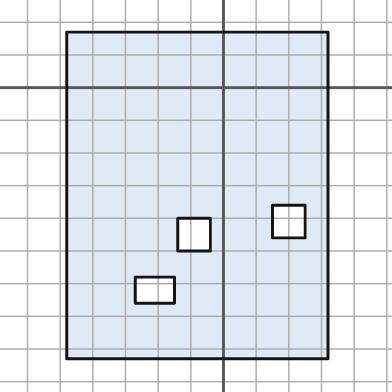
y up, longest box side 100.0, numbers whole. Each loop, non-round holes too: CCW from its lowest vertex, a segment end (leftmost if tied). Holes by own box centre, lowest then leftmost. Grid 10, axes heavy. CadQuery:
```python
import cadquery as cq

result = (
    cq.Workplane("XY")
    .moveTo(-48.0, -83.0)
    .lineTo(32.0, -83.0)
    .lineTo(32.0, 17.0)
    .lineTo(-48.0, 17.0)
    .close()
    .moveTo(-27.0, -66.0)
    .lineTo(-15.0, -66.0)
    .lineTo(-15.0, -58.0)
    .lineTo(-27.0, -58.0)
    .close()
    .moveTo(-14.0, -50.0)
    .lineTo(-4.0, -50.0)
    .lineTo(-4.0, -40.0)
    .lineTo(-14.0, -40.0)
    .close()
    .moveTo(15.0, -46.0)
    .lineTo(25.0, -46.0)
    .lineTo(25.0, -36.0)
    .lineTo(15.0, -36.0)
    .close()
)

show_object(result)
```